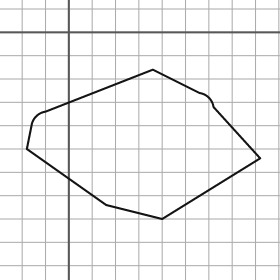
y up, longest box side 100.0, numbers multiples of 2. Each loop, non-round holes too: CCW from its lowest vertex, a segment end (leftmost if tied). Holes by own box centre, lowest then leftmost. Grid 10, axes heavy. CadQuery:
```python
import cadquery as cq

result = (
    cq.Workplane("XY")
    .moveTo(40.0, -80.0)
    .lineTo(82.0, -54.0)
    .lineTo(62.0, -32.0)
    .threePointArc((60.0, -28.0), (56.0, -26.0))
    .lineTo(36.0, -16.0)
    .lineTo(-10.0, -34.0)
    .threePointArc((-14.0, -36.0), (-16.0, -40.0))
    .lineTo(-18.0, -50.0)
    .lineTo(16.0, -74.0)
    .close()
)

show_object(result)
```